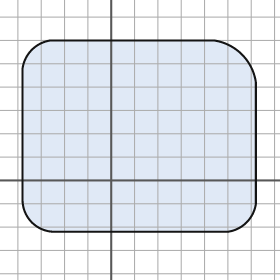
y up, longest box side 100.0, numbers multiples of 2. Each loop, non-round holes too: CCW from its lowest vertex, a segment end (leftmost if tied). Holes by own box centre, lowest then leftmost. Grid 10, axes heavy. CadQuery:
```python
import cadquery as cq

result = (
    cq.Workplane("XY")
    .moveTo(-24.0, -22.0)
    .lineTo(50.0, -22.0)
    .threePointArc((58.0, -18.0), (62.0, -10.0))
    .lineTo(62.0, 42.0)
    .threePointArc((56.0, 54.0), (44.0, 60.0))
    .lineTo(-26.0, 60.0)
    .threePointArc((-34.0, 56.0), (-38.0, 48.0))
    .lineTo(-38.0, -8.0)
    .threePointArc((-34.0, -18.0), (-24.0, -22.0))
    .close()
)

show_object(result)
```